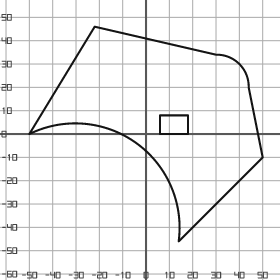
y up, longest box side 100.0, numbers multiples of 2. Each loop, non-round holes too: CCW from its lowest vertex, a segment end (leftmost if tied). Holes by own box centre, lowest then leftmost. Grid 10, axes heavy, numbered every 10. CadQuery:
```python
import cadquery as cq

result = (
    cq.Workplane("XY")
    .moveTo(14.0, -46.0)
    .lineTo(50.0, -10.0)
    .lineTo(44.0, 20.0)
    .threePointArc((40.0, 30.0), (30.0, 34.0))
    .lineTo(-22.0, 46.0)
    .lineTo(-50.0, 0.0)
    .threePointArc((-4.0, -4.0), (14.0, -46.0))
    .close()
    .moveTo(6.0, 0.0)
    .lineTo(18.0, 0.0)
    .lineTo(18.0, 8.0)
    .lineTo(6.0, 8.0)
    .close()
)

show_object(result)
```